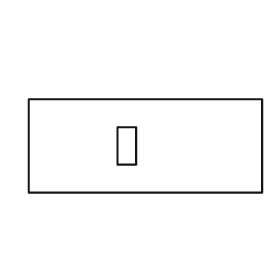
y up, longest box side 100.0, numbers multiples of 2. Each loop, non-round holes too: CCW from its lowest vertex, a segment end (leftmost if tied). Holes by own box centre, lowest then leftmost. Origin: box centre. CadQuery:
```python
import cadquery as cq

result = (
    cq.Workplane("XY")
    .moveTo(-50.0, -20.0)
    .lineTo(50.0, -20.0)
    .lineTo(50.0, 20.0)
    .lineTo(-50.0, 20.0)
    .close()
    .moveTo(-12.0, -8.0)
    .lineTo(-4.0, -8.0)
    .lineTo(-4.0, 8.0)
    .lineTo(-12.0, 8.0)
    .close()
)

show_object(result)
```